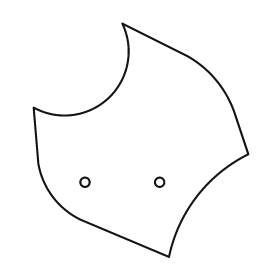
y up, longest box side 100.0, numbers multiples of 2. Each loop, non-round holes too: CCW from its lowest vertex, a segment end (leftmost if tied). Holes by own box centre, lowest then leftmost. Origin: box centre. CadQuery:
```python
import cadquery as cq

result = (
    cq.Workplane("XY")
    .moveTo(12.0, -50.0)
    .threePointArc((24.0, -24.0), (46.0, -6.0))
    .lineTo(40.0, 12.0)
    .threePointArc((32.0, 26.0), (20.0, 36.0))
    .lineTo(-8.0, 50.0)
    .threePointArc((-14.0, 18.0), (-46.0, 14.0))
    .lineTo(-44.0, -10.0)
    .threePointArc((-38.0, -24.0), (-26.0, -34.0))
    .close()
    .moveTo(-24.0, -18.0)
    .circle(2.0)
    .moveTo(8.0, -18.0)
    .circle(2.0)
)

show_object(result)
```